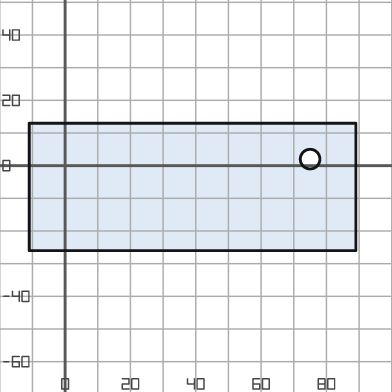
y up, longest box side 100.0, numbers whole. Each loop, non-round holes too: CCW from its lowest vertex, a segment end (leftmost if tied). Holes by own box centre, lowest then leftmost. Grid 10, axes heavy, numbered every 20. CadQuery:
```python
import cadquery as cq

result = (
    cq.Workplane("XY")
    .moveTo(-11.0, -26.0)
    .lineTo(89.0, -26.0)
    .lineTo(89.0, 13.0)
    .lineTo(-11.0, 13.0)
    .close()
    .moveTo(75.0, 2.0)
    .circle(3.0)
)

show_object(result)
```